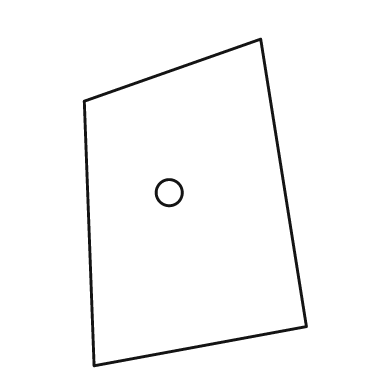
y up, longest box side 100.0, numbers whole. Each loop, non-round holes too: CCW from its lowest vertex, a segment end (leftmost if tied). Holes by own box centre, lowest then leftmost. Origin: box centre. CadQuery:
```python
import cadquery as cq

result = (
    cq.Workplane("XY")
    .moveTo(-31.0, -50.0)
    .lineTo(34.0, -38.0)
    .lineTo(20.0, 50.0)
    .lineTo(-34.0, 31.0)
    .close()
    .moveTo(-8.0, 3.0)
    .circle(4.0)
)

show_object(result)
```